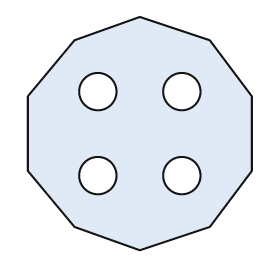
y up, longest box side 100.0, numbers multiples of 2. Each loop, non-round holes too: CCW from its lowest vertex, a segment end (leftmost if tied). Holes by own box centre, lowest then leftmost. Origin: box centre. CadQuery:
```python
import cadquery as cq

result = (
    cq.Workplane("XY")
    .moveTo(0.0, -50.0)
    .lineTo(30.0, -40.0)
    .lineTo(48.0, -16.0)
    .lineTo(48.0, 16.0)
    .lineTo(30.0, 40.0)
    .lineTo(0.0, 50.0)
    .lineTo(-28.0, 40.0)
    .lineTo(-48.0, 16.0)
    .lineTo(-48.0, -16.0)
    .lineTo(-28.0, -40.0)
    .close()
    .moveTo(-18.0, -18.0)
    .circle(8.0)
    .moveTo(18.0, -18.0)
    .circle(8.0)
    .moveTo(-18.0, 18.0)
    .circle(8.0)
    .moveTo(18.0, 18.0)
    .circle(8.0)
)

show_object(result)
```